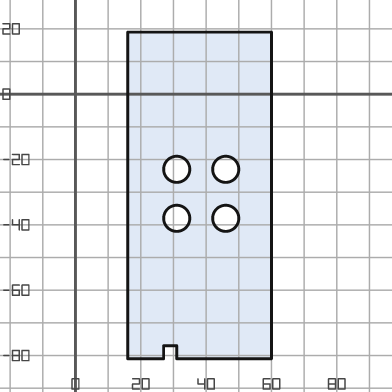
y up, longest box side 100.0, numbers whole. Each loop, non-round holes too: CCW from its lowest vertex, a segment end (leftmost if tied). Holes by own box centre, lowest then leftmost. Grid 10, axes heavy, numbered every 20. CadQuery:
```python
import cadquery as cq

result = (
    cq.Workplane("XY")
    .moveTo(16.0, -81.0)
    .lineTo(27.0, -81.0)
    .lineTo(27.0, -77.0)
    .lineTo(31.0, -77.0)
    .lineTo(31.0, -81.0)
    .lineTo(60.0, -81.0)
    .lineTo(60.0, 19.0)
    .lineTo(16.0, 19.0)
    .close()
    .moveTo(31.0, -38.0)
    .circle(4.0)
    .moveTo(46.0, -38.0)
    .circle(4.0)
    .moveTo(31.0, -23.0)
    .circle(4.0)
    .moveTo(46.0, -23.0)
    .circle(4.0)
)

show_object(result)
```